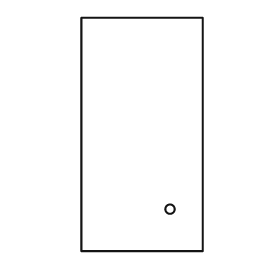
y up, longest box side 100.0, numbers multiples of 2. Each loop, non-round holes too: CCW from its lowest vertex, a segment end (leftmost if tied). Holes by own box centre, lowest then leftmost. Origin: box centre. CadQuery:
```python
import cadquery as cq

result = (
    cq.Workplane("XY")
    .moveTo(-26.0, -50.0)
    .lineTo(26.0, -50.0)
    .lineTo(26.0, 50.0)
    .lineTo(-26.0, 50.0)
    .close()
    .moveTo(12.0, -32.0)
    .circle(2.0)
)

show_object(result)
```